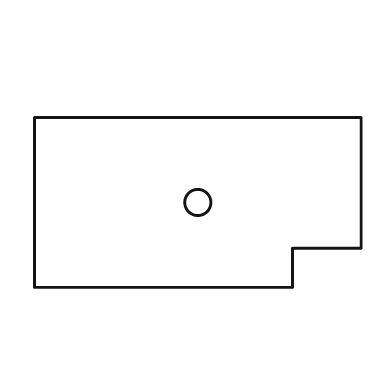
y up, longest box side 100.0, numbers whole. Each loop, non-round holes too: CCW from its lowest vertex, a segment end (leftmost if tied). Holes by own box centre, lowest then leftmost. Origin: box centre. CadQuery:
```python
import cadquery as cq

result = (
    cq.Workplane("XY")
    .moveTo(-50.0, -26.0)
    .lineTo(29.0, -26.0)
    .lineTo(29.0, -14.0)
    .lineTo(50.0, -14.0)
    .lineTo(50.0, 26.0)
    .lineTo(-50.0, 26.0)
    .close()
    .moveTo(0.0, 0.0)
    .circle(4.0)
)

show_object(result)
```